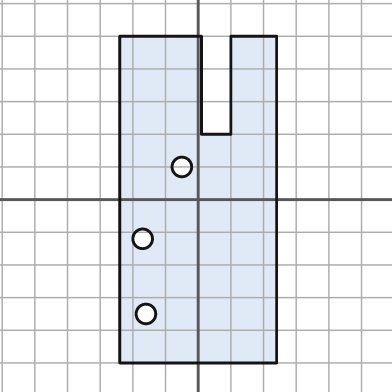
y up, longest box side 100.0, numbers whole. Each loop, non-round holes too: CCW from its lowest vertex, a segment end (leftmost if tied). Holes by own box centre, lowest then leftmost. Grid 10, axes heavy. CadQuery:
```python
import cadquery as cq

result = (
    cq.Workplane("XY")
    .moveTo(-24.0, -50.0)
    .lineTo(24.0, -50.0)
    .lineTo(24.0, 50.0)
    .lineTo(10.0, 50.0)
    .lineTo(10.0, 20.0)
    .lineTo(1.0, 20.0)
    .lineTo(1.0, 50.0)
    .lineTo(-24.0, 50.0)
    .close()
    .moveTo(-16.0, -35.0)
    .circle(3.0)
    .moveTo(-17.0, -12.0)
    .circle(3.0)
    .moveTo(-5.0, 10.0)
    .circle(3.0)
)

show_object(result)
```